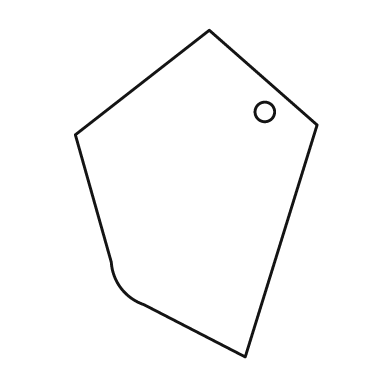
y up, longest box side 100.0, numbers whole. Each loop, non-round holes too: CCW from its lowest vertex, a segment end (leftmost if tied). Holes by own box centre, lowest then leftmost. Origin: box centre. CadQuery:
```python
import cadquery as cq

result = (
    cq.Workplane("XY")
    .moveTo(15.0, -50.0)
    .lineTo(37.0, 21.0)
    .lineTo(4.0, 50.0)
    .lineTo(-37.0, 18.0)
    .lineTo(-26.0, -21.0)
    .threePointArc((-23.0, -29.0), (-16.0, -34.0))
    .close()
    .moveTo(21.0, 25.0)
    .circle(3.0)
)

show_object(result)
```